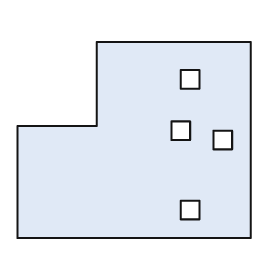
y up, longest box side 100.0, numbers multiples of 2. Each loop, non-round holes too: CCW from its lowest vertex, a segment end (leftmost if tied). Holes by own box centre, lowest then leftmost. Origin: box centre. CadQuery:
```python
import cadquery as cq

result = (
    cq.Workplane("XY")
    .moveTo(-50.0, -42.0)
    .lineTo(50.0, -42.0)
    .lineTo(50.0, 42.0)
    .lineTo(-16.0, 42.0)
    .lineTo(-16.0, 6.0)
    .lineTo(-50.0, 6.0)
    .close()
    .moveTo(20.0, -34.0)
    .lineTo(28.0, -34.0)
    .lineTo(28.0, -26.0)
    .lineTo(20.0, -26.0)
    .close()
    .moveTo(34.0, -4.0)
    .lineTo(42.0, -4.0)
    .lineTo(42.0, 4.0)
    .lineTo(34.0, 4.0)
    .close()
    .moveTo(16.0, 0.0)
    .lineTo(24.0, 0.0)
    .lineTo(24.0, 8.0)
    .lineTo(16.0, 8.0)
    .close()
    .moveTo(20.0, 22.0)
    .lineTo(28.0, 22.0)
    .lineTo(28.0, 30.0)
    .lineTo(20.0, 30.0)
    .close()
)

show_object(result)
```